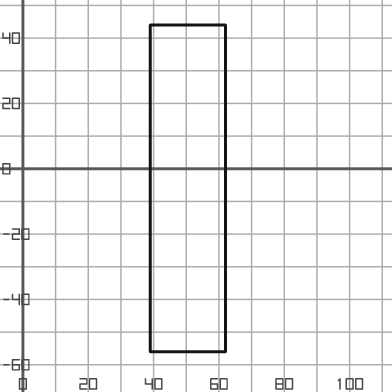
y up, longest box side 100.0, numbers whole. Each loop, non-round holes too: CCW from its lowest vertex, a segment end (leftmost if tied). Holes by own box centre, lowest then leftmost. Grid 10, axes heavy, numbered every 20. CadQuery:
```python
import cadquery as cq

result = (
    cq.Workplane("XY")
    .moveTo(39.0, -56.0)
    .lineTo(62.0, -56.0)
    .lineTo(62.0, 44.0)
    .lineTo(39.0, 44.0)
    .close()
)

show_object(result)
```